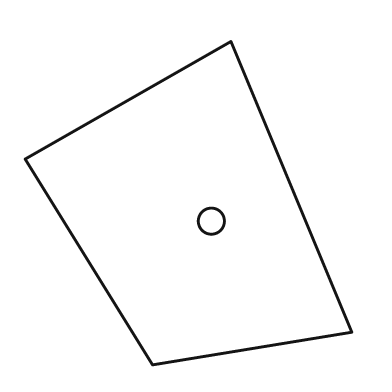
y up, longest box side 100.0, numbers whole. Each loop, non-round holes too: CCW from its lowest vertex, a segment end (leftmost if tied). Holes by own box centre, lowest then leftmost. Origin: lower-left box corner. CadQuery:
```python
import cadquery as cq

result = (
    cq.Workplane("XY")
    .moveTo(39.0, 0.0)
    .lineTo(100.0, 10.0)
    .lineTo(63.0, 99.0)
    .lineTo(0.0, 63.0)
    .close()
    .moveTo(57.0, 44.0)
    .circle(4.0)
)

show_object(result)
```